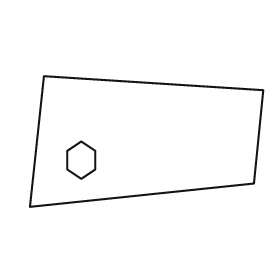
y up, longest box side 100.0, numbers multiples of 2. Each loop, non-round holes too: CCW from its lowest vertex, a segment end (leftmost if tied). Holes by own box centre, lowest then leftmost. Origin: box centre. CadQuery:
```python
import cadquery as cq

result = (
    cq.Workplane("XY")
    .moveTo(-50.0, -28.0)
    .lineTo(46.0, -18.0)
    .lineTo(50.0, 22.0)
    .lineTo(-44.0, 28.0)
    .close()
    .moveTo(-28.0, -16.0)
    .lineTo(-22.0, -12.0)
    .lineTo(-22.0, -4.0)
    .lineTo(-28.0, 0.0)
    .lineTo(-34.0, -4.0)
    .lineTo(-34.0, -12.0)
    .close()
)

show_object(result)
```